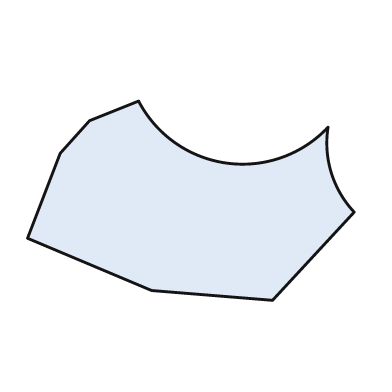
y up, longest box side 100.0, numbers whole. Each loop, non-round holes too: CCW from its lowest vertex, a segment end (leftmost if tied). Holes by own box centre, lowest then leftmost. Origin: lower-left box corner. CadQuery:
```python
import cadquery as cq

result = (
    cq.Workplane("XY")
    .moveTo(75.0, 0.0)
    .lineTo(100.0, 27.0)
    .threePointArc((93.0, 39.0), (92.0, 53.0))
    .threePointArc((61.0, 42.0), (34.0, 61.0))
    .lineTo(19.0, 55.0)
    .lineTo(10.0, 45.0)
    .lineTo(0.0, 19.0)
    .lineTo(38.0, 3.0)
    .close()
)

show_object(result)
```